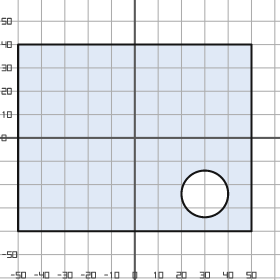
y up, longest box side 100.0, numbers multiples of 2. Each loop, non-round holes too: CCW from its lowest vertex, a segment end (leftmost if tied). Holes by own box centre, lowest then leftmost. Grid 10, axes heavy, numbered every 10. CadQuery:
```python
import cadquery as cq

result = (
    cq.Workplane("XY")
    .moveTo(-50.0, -40.0)
    .lineTo(50.0, -40.0)
    .lineTo(50.0, 40.0)
    .lineTo(-50.0, 40.0)
    .close()
    .moveTo(30.0, -24.0)
    .circle(10.0)
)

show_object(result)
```